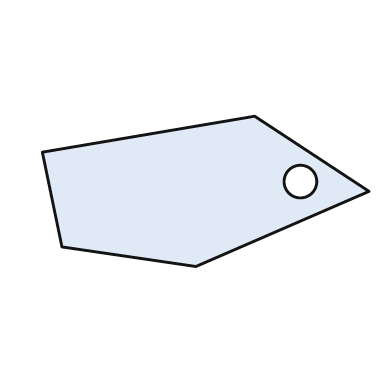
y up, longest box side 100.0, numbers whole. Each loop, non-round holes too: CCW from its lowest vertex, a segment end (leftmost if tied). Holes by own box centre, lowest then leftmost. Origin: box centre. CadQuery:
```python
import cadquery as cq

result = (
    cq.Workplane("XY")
    .moveTo(-3.0, -23.0)
    .lineTo(50.0, 0.0)
    .lineTo(15.0, 23.0)
    .lineTo(-50.0, 12.0)
    .lineTo(-44.0, -17.0)
    .close()
    .moveTo(29.0, 3.0)
    .circle(5.0)
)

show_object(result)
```